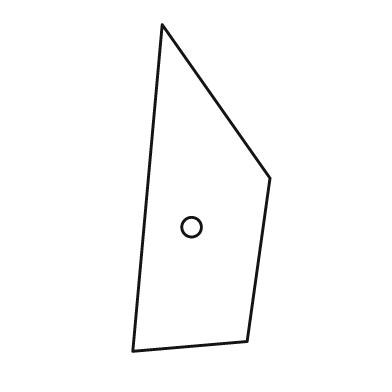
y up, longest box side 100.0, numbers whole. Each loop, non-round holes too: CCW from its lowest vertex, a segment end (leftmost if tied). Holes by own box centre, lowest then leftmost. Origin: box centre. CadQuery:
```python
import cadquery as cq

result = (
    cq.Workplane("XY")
    .moveTo(-21.0, -50.0)
    .lineTo(14.0, -47.0)
    .lineTo(21.0, 3.0)
    .lineTo(-12.0, 50.0)
    .close()
    .moveTo(-3.0, -12.0)
    .circle(3.0)
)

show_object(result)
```